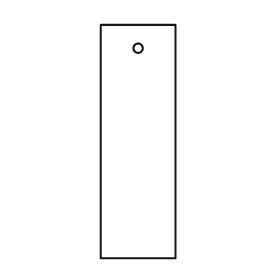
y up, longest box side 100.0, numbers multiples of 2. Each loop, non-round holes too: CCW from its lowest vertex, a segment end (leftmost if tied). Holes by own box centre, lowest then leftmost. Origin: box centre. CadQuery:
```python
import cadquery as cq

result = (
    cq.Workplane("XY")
    .moveTo(-16.0, -50.0)
    .lineTo(16.0, -50.0)
    .lineTo(16.0, 50.0)
    .lineTo(-16.0, 50.0)
    .close()
    .moveTo(0.0, 40.0)
    .circle(2.0)
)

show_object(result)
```